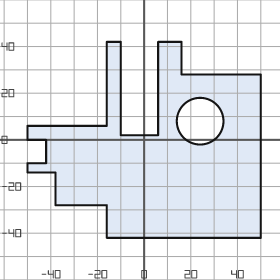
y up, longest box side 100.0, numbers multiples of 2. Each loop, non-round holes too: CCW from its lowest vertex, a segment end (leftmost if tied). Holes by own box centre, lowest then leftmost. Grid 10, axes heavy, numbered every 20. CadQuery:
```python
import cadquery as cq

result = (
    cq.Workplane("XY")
    .moveTo(-16.0, -42.0)
    .lineTo(50.0, -42.0)
    .lineTo(50.0, 28.0)
    .lineTo(16.0, 28.0)
    .lineTo(16.0, 42.0)
    .lineTo(6.0, 42.0)
    .lineTo(6.0, 2.0)
    .lineTo(-10.0, 2.0)
    .lineTo(-10.0, 42.0)
    .lineTo(-16.0, 42.0)
    .lineTo(-16.0, 6.0)
    .lineTo(-50.0, 6.0)
    .lineTo(-50.0, 0.0)
    .lineTo(-42.0, 0.0)
    .lineTo(-42.0, -10.0)
    .lineTo(-50.0, -10.0)
    .lineTo(-50.0, -14.0)
    .lineTo(-38.0, -14.0)
    .lineTo(-38.0, -28.0)
    .lineTo(-16.0, -28.0)
    .close()
    .moveTo(24.0, 8.0)
    .circle(10.0)
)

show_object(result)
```